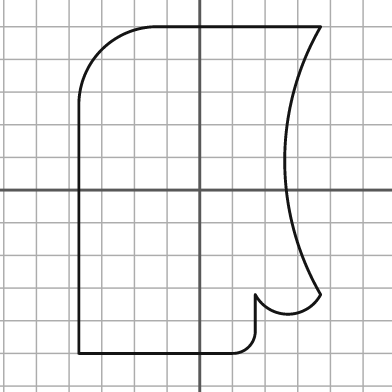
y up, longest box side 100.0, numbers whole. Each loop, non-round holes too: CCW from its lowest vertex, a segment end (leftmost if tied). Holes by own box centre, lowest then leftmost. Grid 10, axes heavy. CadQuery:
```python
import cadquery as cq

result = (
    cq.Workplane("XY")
    .moveTo(-37.0, -50.0)
    .lineTo(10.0, -50.0)
    .threePointArc((15.0, -48.0), (17.0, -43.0))
    .lineTo(17.0, -32.0)
    .threePointArc((27.0, -38.0), (37.0, -32.0))
    .threePointArc((26.0, 9.0), (37.0, 50.0))
    .lineTo(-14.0, 50.0)
    .threePointArc((-30.0, 43.0), (-37.0, 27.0))
    .close()
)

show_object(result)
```